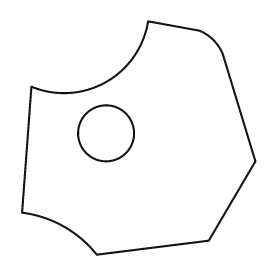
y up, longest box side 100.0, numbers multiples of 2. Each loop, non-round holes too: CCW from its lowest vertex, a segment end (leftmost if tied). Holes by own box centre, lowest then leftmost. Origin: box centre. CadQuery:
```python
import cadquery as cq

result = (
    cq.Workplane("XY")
    .moveTo(-18.0, -50.0)
    .lineTo(30.0, -44.0)
    .lineTo(50.0, -10.0)
    .lineTo(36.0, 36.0)
    .threePointArc((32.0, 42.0), (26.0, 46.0))
    .lineTo(4.0, 50.0)
    .threePointArc((-14.0, 24.0), (-46.0, 22.0))
    .lineTo(-50.0, -32.0)
    .threePointArc((-32.0, -38.0), (-18.0, -50.0))
    .close()
    .moveTo(-14.0, 2.0)
    .circle(12.0)
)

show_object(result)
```